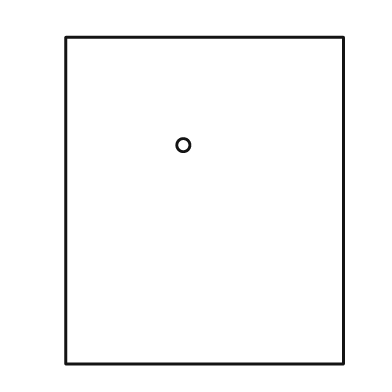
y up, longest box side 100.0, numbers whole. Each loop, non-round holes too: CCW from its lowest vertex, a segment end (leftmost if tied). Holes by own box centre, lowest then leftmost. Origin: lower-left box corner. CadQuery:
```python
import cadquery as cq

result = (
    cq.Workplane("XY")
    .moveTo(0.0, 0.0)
    .lineTo(85.0, 0.0)
    .lineTo(85.0, 100.0)
    .lineTo(0.0, 100.0)
    .close()
    .moveTo(36.0, 67.0)
    .circle(2.0)
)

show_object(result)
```